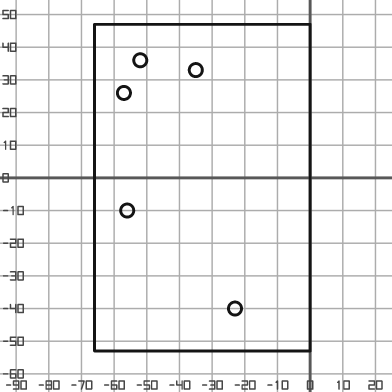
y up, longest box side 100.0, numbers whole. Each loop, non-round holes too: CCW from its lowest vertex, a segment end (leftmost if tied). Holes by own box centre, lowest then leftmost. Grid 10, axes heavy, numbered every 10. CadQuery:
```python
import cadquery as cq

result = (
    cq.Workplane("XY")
    .moveTo(-66.0, -53.0)
    .lineTo(0.0, -53.0)
    .lineTo(0.0, 47.0)
    .lineTo(-66.0, 47.0)
    .close()
    .moveTo(-23.0, -40.0)
    .circle(2.0)
    .moveTo(-56.0, -10.0)
    .circle(2.0)
    .moveTo(-57.0, 26.0)
    .circle(2.0)
    .moveTo(-35.0, 33.0)
    .circle(2.0)
    .moveTo(-52.0, 36.0)
    .circle(2.0)
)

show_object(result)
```